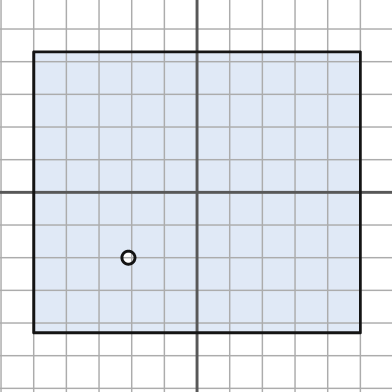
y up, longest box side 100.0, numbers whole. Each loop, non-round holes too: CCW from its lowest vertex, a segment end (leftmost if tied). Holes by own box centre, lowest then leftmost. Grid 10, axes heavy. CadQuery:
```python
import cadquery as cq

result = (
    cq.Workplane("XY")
    .moveTo(-50.0, -43.0)
    .lineTo(50.0, -43.0)
    .lineTo(50.0, 43.0)
    .lineTo(-50.0, 43.0)
    .close()
    .moveTo(-21.0, -20.0)
    .circle(2.0)
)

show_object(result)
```